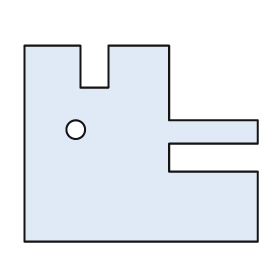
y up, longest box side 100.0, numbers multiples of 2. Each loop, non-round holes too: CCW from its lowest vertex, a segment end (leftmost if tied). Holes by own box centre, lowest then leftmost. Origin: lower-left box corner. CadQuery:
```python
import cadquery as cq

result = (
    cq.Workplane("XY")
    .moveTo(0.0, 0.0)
    .lineTo(100.0, 0.0)
    .lineTo(100.0, 30.0)
    .lineTo(62.0, 30.0)
    .lineTo(62.0, 42.0)
    .lineTo(100.0, 42.0)
    .lineTo(100.0, 52.0)
    .lineTo(62.0, 52.0)
    .lineTo(62.0, 84.0)
    .lineTo(36.0, 84.0)
    .lineTo(36.0, 66.0)
    .lineTo(24.0, 66.0)
    .lineTo(24.0, 84.0)
    .lineTo(0.0, 84.0)
    .close()
    .moveTo(22.0, 48.0)
    .circle(4.0)
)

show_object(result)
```